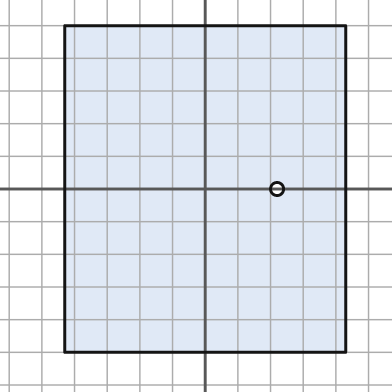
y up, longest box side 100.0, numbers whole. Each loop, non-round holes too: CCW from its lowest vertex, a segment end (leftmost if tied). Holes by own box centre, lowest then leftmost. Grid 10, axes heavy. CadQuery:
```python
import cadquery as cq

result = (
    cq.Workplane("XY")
    .moveTo(-43.0, -50.0)
    .lineTo(43.0, -50.0)
    .lineTo(43.0, 50.0)
    .lineTo(-43.0, 50.0)
    .close()
    .moveTo(22.0, 0.0)
    .circle(2.0)
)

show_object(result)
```